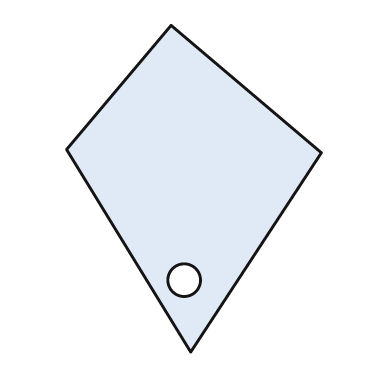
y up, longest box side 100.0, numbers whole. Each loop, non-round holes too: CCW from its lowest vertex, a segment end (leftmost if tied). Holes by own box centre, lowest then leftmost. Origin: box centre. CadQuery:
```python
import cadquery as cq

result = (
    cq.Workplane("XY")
    .moveTo(-1.0, -50.0)
    .lineTo(39.0, 11.0)
    .lineTo(-7.0, 50.0)
    .lineTo(-39.0, 12.0)
    .close()
    .moveTo(-3.0, -28.0)
    .circle(5.0)
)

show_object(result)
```